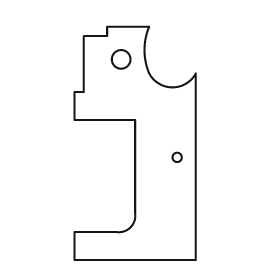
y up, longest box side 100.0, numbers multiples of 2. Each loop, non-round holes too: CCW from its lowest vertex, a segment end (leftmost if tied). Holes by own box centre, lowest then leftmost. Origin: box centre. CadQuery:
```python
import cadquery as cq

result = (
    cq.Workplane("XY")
    .moveTo(-26.0, -50.0)
    .lineTo(26.0, -50.0)
    .lineTo(26.0, 30.0)
    .threePointArc((16.0, 24.0), (6.0, 30.0))
    .threePointArc((4.0, 40.0), (6.0, 50.0))
    .lineTo(-12.0, 50.0)
    .lineTo(-12.0, 46.0)
    .lineTo(-22.0, 46.0)
    .lineTo(-22.0, 22.0)
    .lineTo(-26.0, 22.0)
    .lineTo(-26.0, 10.0)
    .lineTo(0.0, 10.0)
    .lineTo(0.0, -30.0)
    .threePointArc((-2.0, -36.0), (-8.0, -38.0))
    .lineTo(-26.0, -38.0)
    .close()
    .moveTo(18.0, -6.0)
    .circle(2.0)
    .moveTo(-6.0, 36.0)
    .circle(4.0)
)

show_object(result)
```